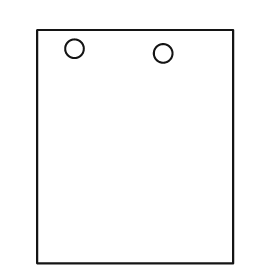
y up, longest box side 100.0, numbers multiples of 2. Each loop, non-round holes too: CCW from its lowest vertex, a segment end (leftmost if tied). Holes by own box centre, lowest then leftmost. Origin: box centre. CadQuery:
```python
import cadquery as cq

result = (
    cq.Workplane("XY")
    .moveTo(-42.0, -50.0)
    .lineTo(42.0, -50.0)
    .lineTo(42.0, 50.0)
    .lineTo(-42.0, 50.0)
    .close()
    .moveTo(12.0, 40.0)
    .circle(4.0)
    .moveTo(-26.0, 42.0)
    .circle(4.0)
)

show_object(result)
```